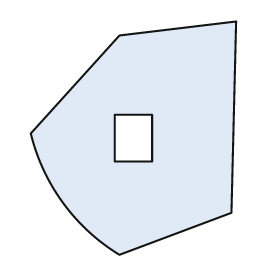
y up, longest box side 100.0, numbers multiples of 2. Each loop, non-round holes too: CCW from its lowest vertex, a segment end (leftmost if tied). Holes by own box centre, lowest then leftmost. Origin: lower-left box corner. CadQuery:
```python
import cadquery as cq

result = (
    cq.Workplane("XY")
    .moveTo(38.0, 0.0)
    .lineTo(86.0, 18.0)
    .lineTo(88.0, 100.0)
    .lineTo(38.0, 94.0)
    .lineTo(0.0, 52.0)
    .threePointArc((14.0, 22.0), (38.0, 0.0))
    .close()
    .moveTo(36.0, 40.0)
    .lineTo(52.0, 40.0)
    .lineTo(52.0, 60.0)
    .lineTo(36.0, 60.0)
    .close()
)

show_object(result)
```